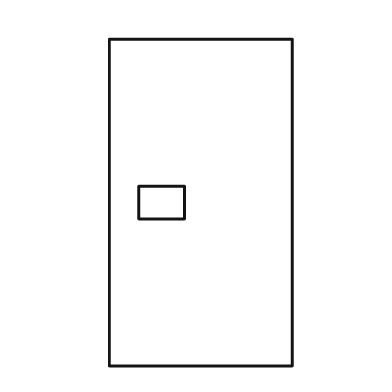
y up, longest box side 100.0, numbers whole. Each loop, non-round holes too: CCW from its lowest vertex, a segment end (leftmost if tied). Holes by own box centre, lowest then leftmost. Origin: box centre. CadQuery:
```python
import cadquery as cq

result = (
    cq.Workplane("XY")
    .moveTo(-28.0, -50.0)
    .lineTo(28.0, -50.0)
    .lineTo(28.0, 50.0)
    .lineTo(-28.0, 50.0)
    .close()
    .moveTo(-19.0, -5.0)
    .lineTo(-5.0, -5.0)
    .lineTo(-5.0, 5.0)
    .lineTo(-19.0, 5.0)
    .close()
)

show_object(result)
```